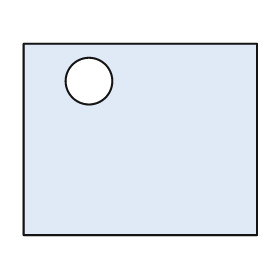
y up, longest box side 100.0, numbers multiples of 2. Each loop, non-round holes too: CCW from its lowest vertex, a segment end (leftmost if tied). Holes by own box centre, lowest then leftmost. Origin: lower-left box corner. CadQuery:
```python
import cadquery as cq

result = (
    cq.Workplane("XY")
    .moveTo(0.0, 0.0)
    .lineTo(100.0, 0.0)
    .lineTo(100.0, 82.0)
    .lineTo(0.0, 82.0)
    .close()
    .moveTo(28.0, 66.0)
    .circle(10.0)
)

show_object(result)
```